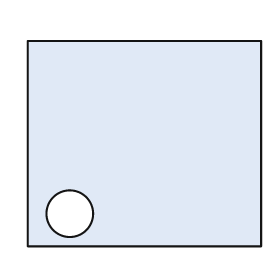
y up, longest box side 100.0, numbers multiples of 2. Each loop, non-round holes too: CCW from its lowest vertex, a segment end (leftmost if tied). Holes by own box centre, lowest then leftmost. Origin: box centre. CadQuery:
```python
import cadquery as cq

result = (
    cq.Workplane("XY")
    .moveTo(-50.0, -44.0)
    .lineTo(50.0, -44.0)
    .lineTo(50.0, 44.0)
    .lineTo(-50.0, 44.0)
    .close()
    .moveTo(-32.0, -30.0)
    .circle(10.0)
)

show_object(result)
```